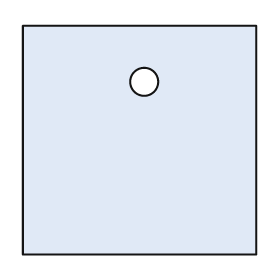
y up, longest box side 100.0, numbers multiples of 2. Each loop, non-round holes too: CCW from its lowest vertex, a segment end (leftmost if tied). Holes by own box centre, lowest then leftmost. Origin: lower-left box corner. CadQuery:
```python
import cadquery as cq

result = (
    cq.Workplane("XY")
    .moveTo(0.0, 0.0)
    .lineTo(100.0, 0.0)
    .lineTo(100.0, 98.0)
    .lineTo(0.0, 98.0)
    .close()
    .moveTo(52.0, 74.0)
    .circle(6.0)
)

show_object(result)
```